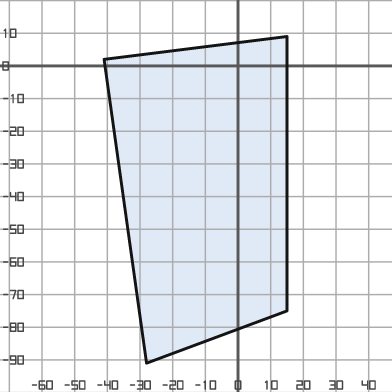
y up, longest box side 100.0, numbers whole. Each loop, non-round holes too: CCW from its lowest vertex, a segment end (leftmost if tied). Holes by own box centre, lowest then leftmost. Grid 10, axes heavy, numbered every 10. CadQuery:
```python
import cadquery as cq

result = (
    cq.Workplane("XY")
    .moveTo(-28.0, -91.0)
    .lineTo(15.0, -75.0)
    .lineTo(15.0, 9.0)
    .lineTo(-41.0, 2.0)
    .close()
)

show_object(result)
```